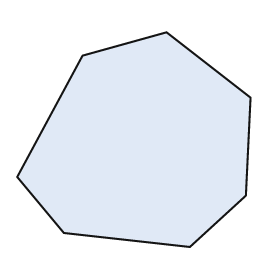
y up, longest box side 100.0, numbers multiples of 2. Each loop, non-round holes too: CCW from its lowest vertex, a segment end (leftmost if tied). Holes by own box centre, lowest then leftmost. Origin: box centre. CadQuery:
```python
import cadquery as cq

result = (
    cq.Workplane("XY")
    .moveTo(24.0, -46.0)
    .lineTo(48.0, -24.0)
    .lineTo(50.0, 18.0)
    .lineTo(14.0, 46.0)
    .lineTo(-22.0, 36.0)
    .lineTo(-50.0, -16.0)
    .lineTo(-30.0, -40.0)
    .close()
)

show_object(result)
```